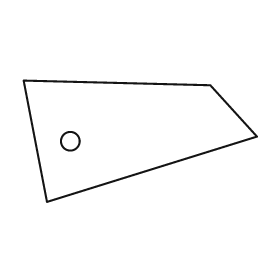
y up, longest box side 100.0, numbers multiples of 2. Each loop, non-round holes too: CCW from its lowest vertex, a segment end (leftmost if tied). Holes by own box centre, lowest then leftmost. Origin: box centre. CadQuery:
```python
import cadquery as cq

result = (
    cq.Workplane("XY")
    .moveTo(-40.0, -26.0)
    .lineTo(50.0, 2.0)
    .lineTo(30.0, 24.0)
    .lineTo(-50.0, 26.0)
    .close()
    .moveTo(-30.0, 0.0)
    .circle(4.0)
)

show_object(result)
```